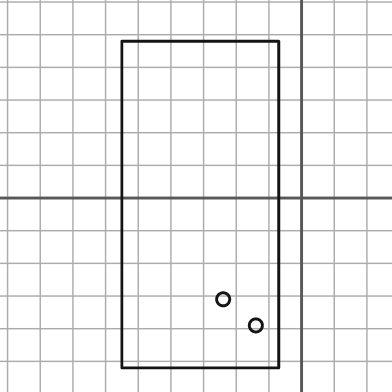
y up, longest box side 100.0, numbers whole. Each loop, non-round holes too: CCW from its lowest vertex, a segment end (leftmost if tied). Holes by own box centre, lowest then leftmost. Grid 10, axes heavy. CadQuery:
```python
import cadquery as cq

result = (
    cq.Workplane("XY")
    .moveTo(-55.0, -52.0)
    .lineTo(-7.0, -52.0)
    .lineTo(-7.0, 48.0)
    .lineTo(-55.0, 48.0)
    .close()
    .moveTo(-14.0, -39.0)
    .circle(2.0)
    .moveTo(-24.0, -31.0)
    .circle(2.0)
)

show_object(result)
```